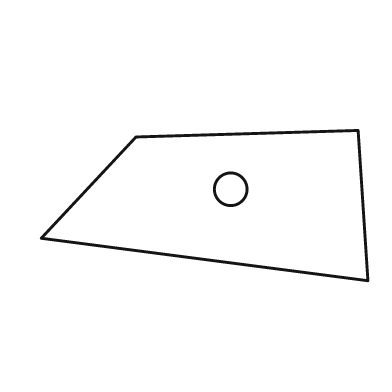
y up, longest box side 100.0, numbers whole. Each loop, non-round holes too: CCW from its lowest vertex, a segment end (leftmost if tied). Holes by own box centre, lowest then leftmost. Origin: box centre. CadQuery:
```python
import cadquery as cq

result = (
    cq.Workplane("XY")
    .moveTo(50.0, -23.0)
    .lineTo(47.0, 23.0)
    .lineTo(-21.0, 21.0)
    .lineTo(-50.0, -10.0)
    .close()
    .moveTo(8.0, 5.0)
    .circle(5.0)
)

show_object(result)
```